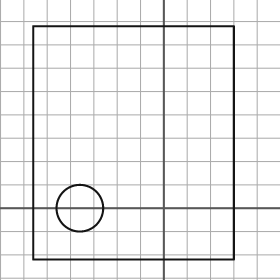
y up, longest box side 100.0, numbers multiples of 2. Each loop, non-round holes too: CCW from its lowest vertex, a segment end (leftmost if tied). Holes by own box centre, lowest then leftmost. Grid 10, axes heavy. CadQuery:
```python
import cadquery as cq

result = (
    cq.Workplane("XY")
    .moveTo(-56.0, -22.0)
    .lineTo(30.0, -22.0)
    .lineTo(30.0, 78.0)
    .lineTo(-56.0, 78.0)
    .close()
    .moveTo(-36.0, 0.0)
    .circle(10.0)
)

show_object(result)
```